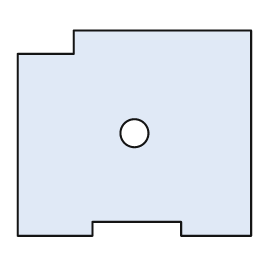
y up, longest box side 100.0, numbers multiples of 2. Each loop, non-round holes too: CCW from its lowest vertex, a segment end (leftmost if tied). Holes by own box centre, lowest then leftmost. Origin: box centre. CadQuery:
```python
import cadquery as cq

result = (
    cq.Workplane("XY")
    .moveTo(-50.0, -44.0)
    .lineTo(-18.0, -44.0)
    .lineTo(-18.0, -38.0)
    .lineTo(20.0, -38.0)
    .lineTo(20.0, -44.0)
    .lineTo(50.0, -44.0)
    .lineTo(50.0, 44.0)
    .lineTo(-26.0, 44.0)
    .lineTo(-26.0, 34.0)
    .lineTo(-50.0, 34.0)
    .close()
    .moveTo(0.0, 0.0)
    .circle(6.0)
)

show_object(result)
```